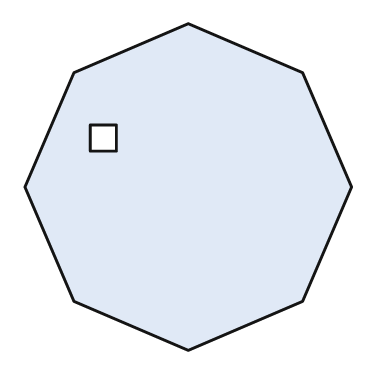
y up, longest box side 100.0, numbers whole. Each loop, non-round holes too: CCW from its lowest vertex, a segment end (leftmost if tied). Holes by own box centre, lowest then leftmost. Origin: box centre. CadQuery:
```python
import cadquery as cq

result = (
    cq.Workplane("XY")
    .moveTo(0.0, -50.0)
    .lineTo(35.0, -35.0)
    .lineTo(50.0, 0.0)
    .lineTo(35.0, 35.0)
    .lineTo(0.0, 50.0)
    .lineTo(-35.0, 35.0)
    .lineTo(-50.0, 0.0)
    .lineTo(-35.0, -35.0)
    .close()
    .moveTo(-30.0, 11.0)
    .lineTo(-22.0, 11.0)
    .lineTo(-22.0, 19.0)
    .lineTo(-30.0, 19.0)
    .close()
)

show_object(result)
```